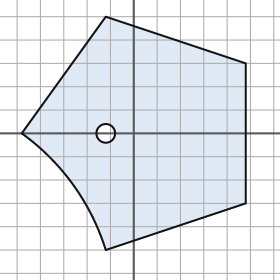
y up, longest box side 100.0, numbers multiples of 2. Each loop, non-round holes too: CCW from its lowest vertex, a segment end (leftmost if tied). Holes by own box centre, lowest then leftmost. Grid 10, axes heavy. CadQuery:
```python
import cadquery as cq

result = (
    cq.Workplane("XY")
    .moveTo(-12.0, -50.0)
    .lineTo(48.0, -30.0)
    .lineTo(48.0, 30.0)
    .lineTo(-12.0, 50.0)
    .lineTo(-48.0, 0.0)
    .threePointArc((-26.0, -22.0), (-12.0, -50.0))
    .close()
    .moveTo(-12.0, 0.0)
    .circle(4.0)
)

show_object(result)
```